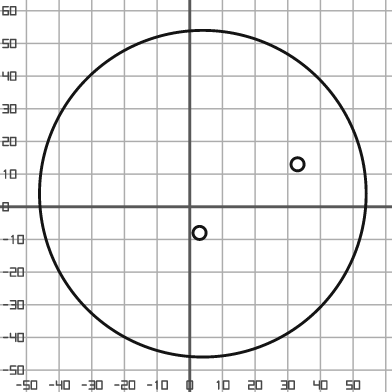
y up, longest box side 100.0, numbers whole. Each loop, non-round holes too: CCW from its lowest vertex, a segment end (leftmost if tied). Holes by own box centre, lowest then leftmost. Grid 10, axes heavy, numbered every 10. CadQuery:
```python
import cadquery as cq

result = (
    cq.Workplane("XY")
    .moveTo(4.0, 4.0)
    .circle(50.0)
    .moveTo(3.0, -8.0)
    .circle(2.0)
    .moveTo(33.0, 13.0)
    .circle(2.0)
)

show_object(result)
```